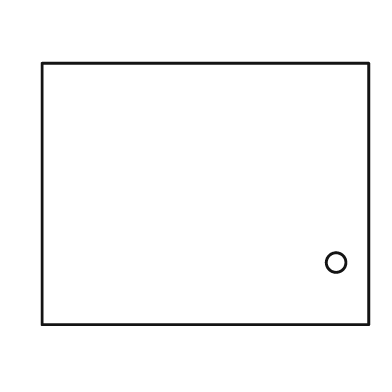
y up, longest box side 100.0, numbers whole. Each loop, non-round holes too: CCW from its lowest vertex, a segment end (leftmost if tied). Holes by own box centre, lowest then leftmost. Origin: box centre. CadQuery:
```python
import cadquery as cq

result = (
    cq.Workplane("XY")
    .moveTo(-50.0, -40.0)
    .lineTo(50.0, -40.0)
    .lineTo(50.0, 40.0)
    .lineTo(-50.0, 40.0)
    .close()
    .moveTo(40.0, -21.0)
    .circle(3.0)
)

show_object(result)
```